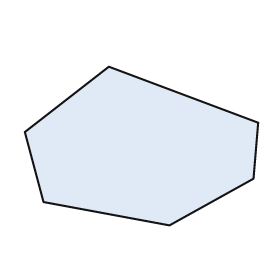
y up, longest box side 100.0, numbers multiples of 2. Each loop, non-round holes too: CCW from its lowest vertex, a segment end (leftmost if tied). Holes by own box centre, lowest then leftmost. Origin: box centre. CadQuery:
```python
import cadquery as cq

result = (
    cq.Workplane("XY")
    .moveTo(12.0, -34.0)
    .lineTo(48.0, -14.0)
    .lineTo(50.0, 10.0)
    .lineTo(-14.0, 34.0)
    .lineTo(-50.0, 6.0)
    .lineTo(-42.0, -24.0)
    .close()
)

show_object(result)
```